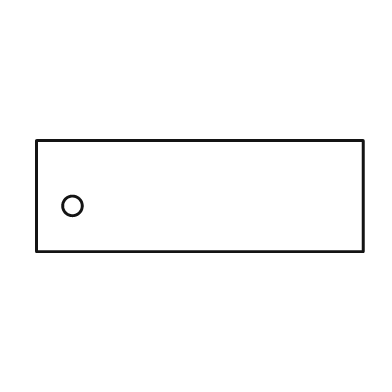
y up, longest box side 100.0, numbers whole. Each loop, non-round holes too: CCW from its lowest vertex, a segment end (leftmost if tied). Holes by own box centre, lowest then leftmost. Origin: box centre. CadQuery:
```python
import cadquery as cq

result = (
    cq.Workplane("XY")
    .moveTo(-50.0, -17.0)
    .lineTo(50.0, -17.0)
    .lineTo(50.0, 17.0)
    .lineTo(-50.0, 17.0)
    .close()
    .moveTo(-39.0, -3.0)
    .circle(3.0)
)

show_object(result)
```